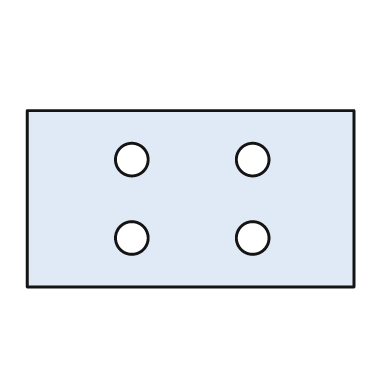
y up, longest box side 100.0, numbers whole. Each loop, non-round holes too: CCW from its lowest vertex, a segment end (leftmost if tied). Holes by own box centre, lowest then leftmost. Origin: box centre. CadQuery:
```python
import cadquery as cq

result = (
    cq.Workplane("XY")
    .moveTo(-50.0, -27.0)
    .lineTo(50.0, -27.0)
    .lineTo(50.0, 27.0)
    .lineTo(-50.0, 27.0)
    .close()
    .moveTo(-18.0, -12.0)
    .circle(5.0)
    .moveTo(19.0, -12.0)
    .circle(5.0)
    .moveTo(-18.0, 12.0)
    .circle(5.0)
    .moveTo(19.0, 12.0)
    .circle(5.0)
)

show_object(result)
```